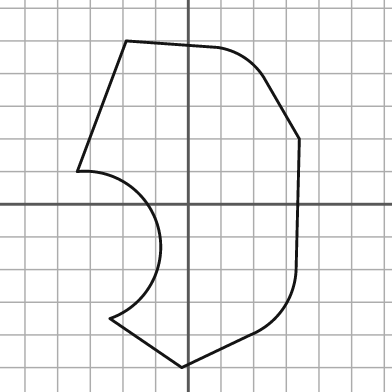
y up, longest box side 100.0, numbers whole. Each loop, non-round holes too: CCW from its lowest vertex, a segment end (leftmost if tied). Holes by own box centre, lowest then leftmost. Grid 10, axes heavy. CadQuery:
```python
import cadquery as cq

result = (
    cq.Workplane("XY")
    .moveTo(-2.0, -50.0)
    .lineTo(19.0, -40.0)
    .threePointArc((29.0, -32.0), (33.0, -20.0))
    .lineTo(34.0, 20.0)
    .lineTo(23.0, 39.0)
    .threePointArc((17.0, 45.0), (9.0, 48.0))
    .lineTo(-19.0, 50.0)
    .lineTo(-34.0, 10.0)
    .threePointArc((-9.0, -8.0), (-24.0, -35.0))
    .close()
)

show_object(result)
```